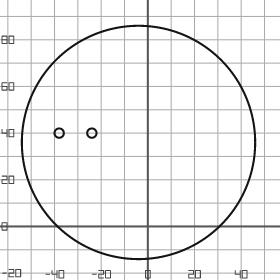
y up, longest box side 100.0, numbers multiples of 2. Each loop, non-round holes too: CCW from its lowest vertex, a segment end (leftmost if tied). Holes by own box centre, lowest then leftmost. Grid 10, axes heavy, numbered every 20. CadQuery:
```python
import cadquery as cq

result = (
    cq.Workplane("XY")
    .moveTo(-4.0, 36.0)
    .circle(50.0)
    .moveTo(-38.0, 40.0)
    .circle(2.0)
    .moveTo(-24.0, 40.0)
    .circle(2.0)
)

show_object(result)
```